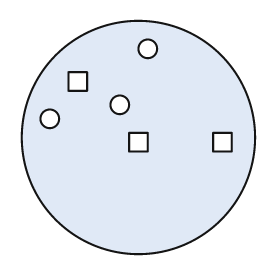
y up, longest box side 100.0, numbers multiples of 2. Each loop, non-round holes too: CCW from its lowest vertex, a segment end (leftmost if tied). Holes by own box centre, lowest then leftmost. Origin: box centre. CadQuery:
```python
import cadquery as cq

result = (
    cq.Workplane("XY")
    .moveTo(0.0, 0.0)
    .circle(50.0)
    .moveTo(-4.0, -6.0)
    .lineTo(4.0, -6.0)
    .lineTo(4.0, 2.0)
    .lineTo(-4.0, 2.0)
    .close()
    .moveTo(32.0, -6.0)
    .lineTo(40.0, -6.0)
    .lineTo(40.0, 2.0)
    .lineTo(32.0, 2.0)
    .close()
    .moveTo(-38.0, 8.0)
    .circle(4.0)
    .moveTo(-8.0, 14.0)
    .circle(4.0)
    .moveTo(-30.0, 20.0)
    .lineTo(-22.0, 20.0)
    .lineTo(-22.0, 28.0)
    .lineTo(-30.0, 28.0)
    .close()
    .moveTo(4.0, 38.0)
    .circle(4.0)
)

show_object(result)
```